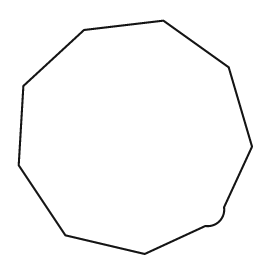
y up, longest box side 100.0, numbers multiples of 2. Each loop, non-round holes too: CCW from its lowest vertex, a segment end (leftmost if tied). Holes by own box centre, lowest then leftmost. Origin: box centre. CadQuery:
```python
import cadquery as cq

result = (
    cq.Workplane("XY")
    .moveTo(4.0, -50.0)
    .lineTo(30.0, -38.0)
    .threePointArc((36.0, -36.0), (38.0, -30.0))
    .lineTo(50.0, -4.0)
    .lineTo(40.0, 30.0)
    .lineTo(12.0, 50.0)
    .lineTo(-22.0, 46.0)
    .lineTo(-48.0, 22.0)
    .lineTo(-50.0, -12.0)
    .lineTo(-30.0, -42.0)
    .close()
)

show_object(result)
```